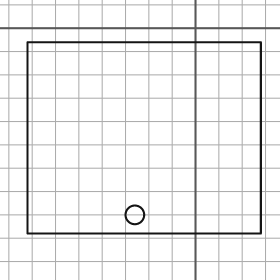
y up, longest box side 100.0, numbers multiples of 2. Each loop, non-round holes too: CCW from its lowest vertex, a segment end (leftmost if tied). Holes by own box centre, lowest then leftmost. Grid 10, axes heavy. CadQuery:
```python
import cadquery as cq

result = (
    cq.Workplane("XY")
    .moveTo(-72.0, -88.0)
    .lineTo(28.0, -88.0)
    .lineTo(28.0, -6.0)
    .lineTo(-72.0, -6.0)
    .close()
    .moveTo(-26.0, -80.0)
    .circle(4.0)
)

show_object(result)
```